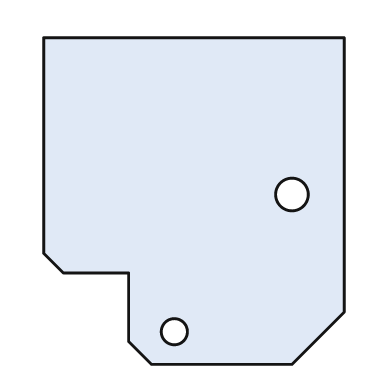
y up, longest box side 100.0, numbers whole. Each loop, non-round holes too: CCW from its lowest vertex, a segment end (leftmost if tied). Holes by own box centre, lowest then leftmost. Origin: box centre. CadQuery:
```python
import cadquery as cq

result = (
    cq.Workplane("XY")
    .moveTo(-13.0, -50.0)
    .lineTo(30.0, -50.0)
    .lineTo(46.0, -34.0)
    .lineTo(46.0, 50.0)
    .lineTo(-46.0, 50.0)
    .lineTo(-46.0, -16.0)
    .lineTo(-40.0, -22.0)
    .lineTo(-20.0, -22.0)
    .lineTo(-20.0, -43.0)
    .close()
    .moveTo(-6.0, -40.0)
    .circle(4.0)
    .moveTo(30.0, 2.0)
    .circle(5.0)
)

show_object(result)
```